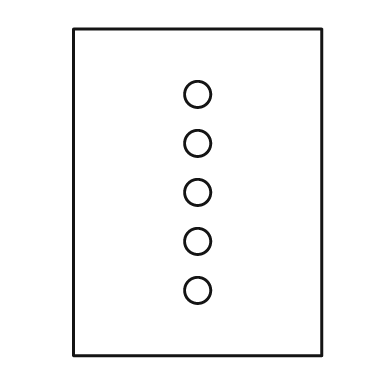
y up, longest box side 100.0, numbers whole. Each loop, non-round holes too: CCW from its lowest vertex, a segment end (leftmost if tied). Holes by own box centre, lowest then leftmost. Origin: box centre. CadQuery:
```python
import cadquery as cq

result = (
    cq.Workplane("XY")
    .moveTo(-38.0, -50.0)
    .lineTo(38.0, -50.0)
    .lineTo(38.0, 50.0)
    .lineTo(-38.0, 50.0)
    .close()
    .moveTo(0.0, -30.0)
    .circle(4.0)
    .moveTo(0.0, -15.0)
    .circle(4.0)
    .moveTo(0.0, 0.0)
    .circle(4.0)
    .moveTo(0.0, 15.0)
    .circle(4.0)
    .moveTo(0.0, 30.0)
    .circle(4.0)
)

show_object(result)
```